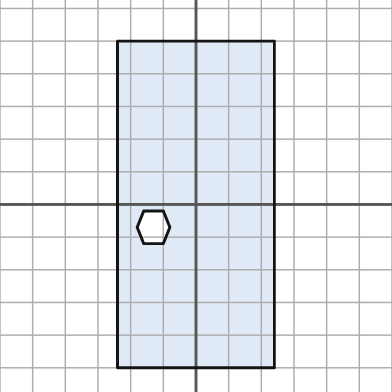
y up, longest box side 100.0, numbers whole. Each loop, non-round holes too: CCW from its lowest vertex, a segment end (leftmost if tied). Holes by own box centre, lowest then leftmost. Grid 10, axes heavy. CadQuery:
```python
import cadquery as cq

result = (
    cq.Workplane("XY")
    .moveTo(-24.0, -50.0)
    .lineTo(24.0, -50.0)
    .lineTo(24.0, 50.0)
    .lineTo(-24.0, 50.0)
    .close()
    .moveTo(-16.0, -12.0)
    .lineTo(-10.0, -12.0)
    .lineTo(-8.0, -7.0)
    .lineTo(-10.0, -2.0)
    .lineTo(-16.0, -2.0)
    .lineTo(-18.0, -7.0)
    .close()
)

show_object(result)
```